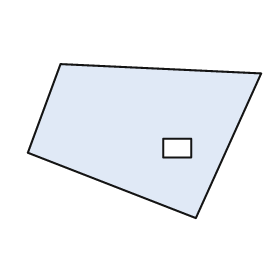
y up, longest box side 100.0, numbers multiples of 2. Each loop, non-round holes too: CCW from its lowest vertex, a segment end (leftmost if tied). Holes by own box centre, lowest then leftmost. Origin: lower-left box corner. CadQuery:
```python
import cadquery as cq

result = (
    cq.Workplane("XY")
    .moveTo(72.0, 0.0)
    .lineTo(100.0, 62.0)
    .lineTo(14.0, 66.0)
    .lineTo(0.0, 28.0)
    .close()
    .moveTo(58.0, 26.0)
    .lineTo(70.0, 26.0)
    .lineTo(70.0, 34.0)
    .lineTo(58.0, 34.0)
    .close()
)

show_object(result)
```